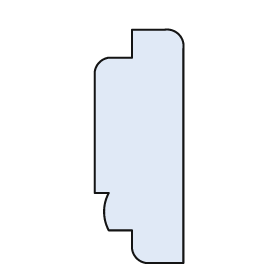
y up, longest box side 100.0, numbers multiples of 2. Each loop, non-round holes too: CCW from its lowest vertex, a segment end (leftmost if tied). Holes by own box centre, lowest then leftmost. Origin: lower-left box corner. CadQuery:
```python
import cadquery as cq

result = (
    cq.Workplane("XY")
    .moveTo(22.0, 0.0)
    .lineTo(38.0, 0.0)
    .lineTo(38.0, 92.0)
    .threePointArc((36.0, 98.0), (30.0, 100.0))
    .lineTo(16.0, 100.0)
    .lineTo(16.0, 88.0)
    .lineTo(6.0, 88.0)
    .threePointArc((2.0, 86.0), (0.0, 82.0))
    .lineTo(0.0, 30.0)
    .lineTo(6.0, 30.0)
    .threePointArc((4.0, 22.0), (6.0, 14.0))
    .lineTo(16.0, 14.0)
    .lineTo(16.0, 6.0)
    .threePointArc((18.0, 2.0), (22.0, 0.0))
    .close()
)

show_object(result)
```